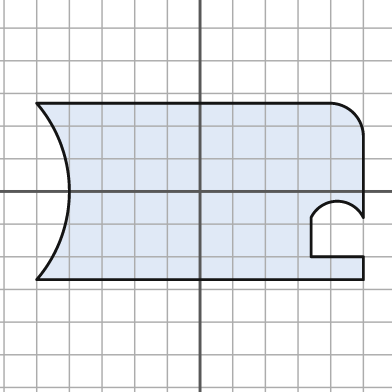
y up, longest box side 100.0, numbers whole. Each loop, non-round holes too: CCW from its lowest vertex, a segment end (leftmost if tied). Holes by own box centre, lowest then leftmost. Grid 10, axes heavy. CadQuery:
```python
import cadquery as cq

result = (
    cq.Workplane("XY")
    .moveTo(-50.0, -27.0)
    .lineTo(50.0, -27.0)
    .lineTo(50.0, -20.0)
    .lineTo(34.0, -20.0)
    .lineTo(34.0, -8.0)
    .threePointArc((42.0, -3.0), (50.0, -8.0))
    .lineTo(50.0, 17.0)
    .threePointArc((47.0, 24.0), (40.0, 27.0))
    .lineTo(-50.0, 27.0)
    .threePointArc((-40.0, 0.0), (-50.0, -27.0))
    .close()
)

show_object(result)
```